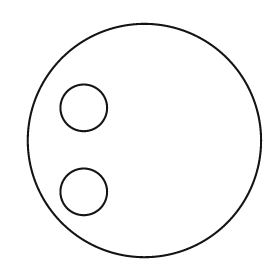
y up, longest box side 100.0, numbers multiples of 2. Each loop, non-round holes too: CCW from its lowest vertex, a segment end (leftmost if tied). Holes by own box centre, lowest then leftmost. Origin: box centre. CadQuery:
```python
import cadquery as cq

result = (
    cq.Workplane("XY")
    .moveTo(0.0, 0.0)
    .circle(50.0)
    .moveTo(-26.0, -22.0)
    .circle(10.0)
    .moveTo(-26.0, 14.0)
    .circle(10.0)
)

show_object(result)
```